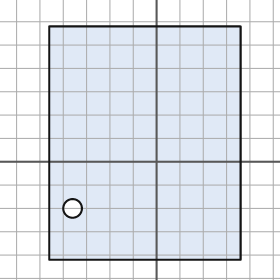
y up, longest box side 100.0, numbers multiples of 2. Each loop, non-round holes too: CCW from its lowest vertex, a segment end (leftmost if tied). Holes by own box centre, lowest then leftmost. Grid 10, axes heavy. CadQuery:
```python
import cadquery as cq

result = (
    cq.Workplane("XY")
    .moveTo(-46.0, -42.0)
    .lineTo(36.0, -42.0)
    .lineTo(36.0, 58.0)
    .lineTo(-46.0, 58.0)
    .close()
    .moveTo(-36.0, -20.0)
    .circle(4.0)
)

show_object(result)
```